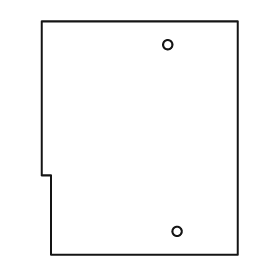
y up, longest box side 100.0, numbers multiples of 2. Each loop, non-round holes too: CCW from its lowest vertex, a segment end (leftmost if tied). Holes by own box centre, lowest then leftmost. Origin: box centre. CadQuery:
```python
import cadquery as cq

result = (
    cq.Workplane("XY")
    .moveTo(-38.0, -50.0)
    .lineTo(42.0, -50.0)
    .lineTo(42.0, 50.0)
    .lineTo(-42.0, 50.0)
    .lineTo(-42.0, -16.0)
    .lineTo(-38.0, -16.0)
    .close()
    .moveTo(16.0, -40.0)
    .circle(2.0)
    .moveTo(12.0, 40.0)
    .circle(2.0)
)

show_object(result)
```